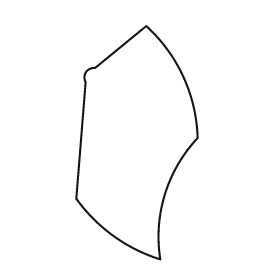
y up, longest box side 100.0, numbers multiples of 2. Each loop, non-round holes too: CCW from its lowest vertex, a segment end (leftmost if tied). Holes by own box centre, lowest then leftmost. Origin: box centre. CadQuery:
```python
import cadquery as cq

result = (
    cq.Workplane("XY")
    .moveTo(10.0, -50.0)
    .threePointArc((12.0, -22.0), (26.0, 2.0))
    .threePointArc((20.0, 28.0), (4.0, 50.0))
    .lineTo(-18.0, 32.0)
    .threePointArc((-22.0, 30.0), (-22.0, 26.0))
    .lineTo(-26.0, -24.0)
    .threePointArc((-10.0, -40.0), (10.0, -50.0))
    .close()
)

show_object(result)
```